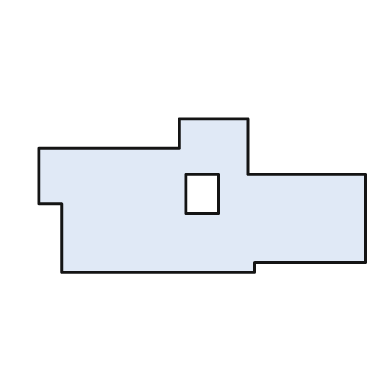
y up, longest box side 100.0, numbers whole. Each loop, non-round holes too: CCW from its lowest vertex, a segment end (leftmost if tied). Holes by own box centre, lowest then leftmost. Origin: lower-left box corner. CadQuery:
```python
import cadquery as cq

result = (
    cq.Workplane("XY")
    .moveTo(7.0, 0.0)
    .lineTo(66.0, 0.0)
    .lineTo(66.0, 3.0)
    .lineTo(100.0, 3.0)
    .lineTo(100.0, 30.0)
    .lineTo(64.0, 30.0)
    .lineTo(64.0, 47.0)
    .lineTo(43.0, 47.0)
    .lineTo(43.0, 38.0)
    .lineTo(0.0, 38.0)
    .lineTo(0.0, 21.0)
    .lineTo(7.0, 21.0)
    .close()
    .moveTo(45.0, 18.0)
    .lineTo(55.0, 18.0)
    .lineTo(55.0, 30.0)
    .lineTo(45.0, 30.0)
    .close()
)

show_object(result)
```